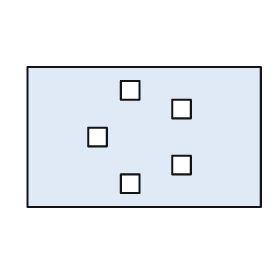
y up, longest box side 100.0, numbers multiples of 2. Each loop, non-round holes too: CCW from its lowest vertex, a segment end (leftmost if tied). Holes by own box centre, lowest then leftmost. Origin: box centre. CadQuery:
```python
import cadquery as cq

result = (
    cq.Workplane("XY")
    .moveTo(-50.0, -30.0)
    .lineTo(50.0, -30.0)
    .lineTo(50.0, 30.0)
    .lineTo(-50.0, 30.0)
    .close()
    .moveTo(-10.0, -24.0)
    .lineTo(-2.0, -24.0)
    .lineTo(-2.0, -16.0)
    .lineTo(-10.0, -16.0)
    .close()
    .moveTo(12.0, -16.0)
    .lineTo(20.0, -16.0)
    .lineTo(20.0, -8.0)
    .lineTo(12.0, -8.0)
    .close()
    .moveTo(-24.0, -4.0)
    .lineTo(-16.0, -4.0)
    .lineTo(-16.0, 4.0)
    .lineTo(-24.0, 4.0)
    .close()
    .moveTo(12.0, 8.0)
    .lineTo(20.0, 8.0)
    .lineTo(20.0, 16.0)
    .lineTo(12.0, 16.0)
    .close()
    .moveTo(-10.0, 16.0)
    .lineTo(-2.0, 16.0)
    .lineTo(-2.0, 24.0)
    .lineTo(-10.0, 24.0)
    .close()
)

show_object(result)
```